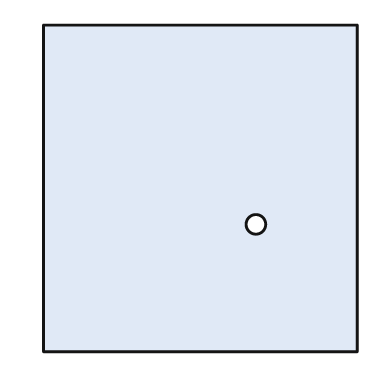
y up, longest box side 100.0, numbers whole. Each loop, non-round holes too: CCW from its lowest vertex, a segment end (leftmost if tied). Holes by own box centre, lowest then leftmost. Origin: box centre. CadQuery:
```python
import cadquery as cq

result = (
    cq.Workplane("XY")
    .moveTo(-48.0, -50.0)
    .lineTo(48.0, -50.0)
    .lineTo(48.0, 50.0)
    .lineTo(-48.0, 50.0)
    .close()
    .moveTo(17.0, -11.0)
    .circle(3.0)
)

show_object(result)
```